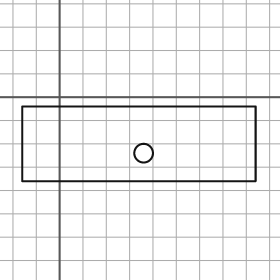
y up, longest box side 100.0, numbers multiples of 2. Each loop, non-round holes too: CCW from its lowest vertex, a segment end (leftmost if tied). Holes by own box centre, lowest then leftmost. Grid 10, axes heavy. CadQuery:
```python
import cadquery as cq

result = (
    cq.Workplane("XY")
    .moveTo(-16.0, -36.0)
    .lineTo(84.0, -36.0)
    .lineTo(84.0, -4.0)
    .lineTo(-16.0, -4.0)
    .close()
    .moveTo(36.0, -24.0)
    .circle(4.0)
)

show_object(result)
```